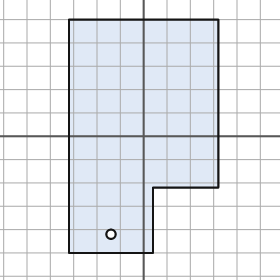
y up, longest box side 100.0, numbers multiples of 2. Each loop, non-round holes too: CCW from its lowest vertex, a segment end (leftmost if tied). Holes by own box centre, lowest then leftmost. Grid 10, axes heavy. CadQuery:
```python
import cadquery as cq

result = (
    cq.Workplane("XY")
    .moveTo(-32.0, -50.0)
    .lineTo(4.0, -50.0)
    .lineTo(4.0, -22.0)
    .lineTo(32.0, -22.0)
    .lineTo(32.0, 50.0)
    .lineTo(-32.0, 50.0)
    .close()
    .moveTo(-14.0, -42.0)
    .circle(2.0)
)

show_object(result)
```